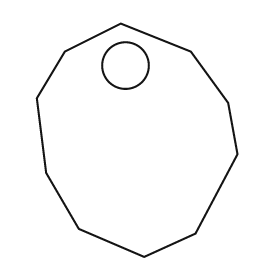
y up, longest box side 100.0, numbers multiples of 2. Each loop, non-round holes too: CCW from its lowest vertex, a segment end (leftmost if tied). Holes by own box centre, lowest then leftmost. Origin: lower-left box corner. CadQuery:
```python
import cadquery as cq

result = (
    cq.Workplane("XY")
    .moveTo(46.0, 0.0)
    .lineTo(68.0, 10.0)
    .lineTo(86.0, 44.0)
    .lineTo(82.0, 66.0)
    .lineTo(66.0, 88.0)
    .lineTo(36.0, 100.0)
    .lineTo(12.0, 88.0)
    .lineTo(0.0, 68.0)
    .lineTo(4.0, 36.0)
    .lineTo(18.0, 12.0)
    .close()
    .moveTo(38.0, 82.0)
    .circle(10.0)
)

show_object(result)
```